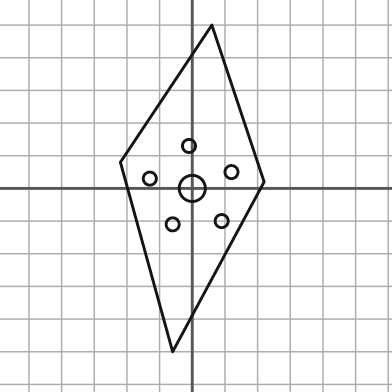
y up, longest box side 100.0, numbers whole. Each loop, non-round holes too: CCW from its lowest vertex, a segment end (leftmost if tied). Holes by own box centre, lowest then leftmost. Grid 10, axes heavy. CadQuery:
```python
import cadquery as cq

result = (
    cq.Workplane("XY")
    .moveTo(-6.0, -50.0)
    .lineTo(22.0, 2.0)
    .lineTo(6.0, 50.0)
    .lineTo(-22.0, 8.0)
    .close()
    .moveTo(-6.0, -11.0)
    .circle(2.0)
    .moveTo(9.0, -10.0)
    .circle(2.0)
    .moveTo(0.0, 0.0)
    .circle(4.0)
    .moveTo(-13.0, 3.0)
    .circle(2.0)
    .moveTo(12.0, 5.0)
    .circle(2.0)
    .moveTo(-1.0, 13.0)
    .circle(2.0)
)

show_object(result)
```